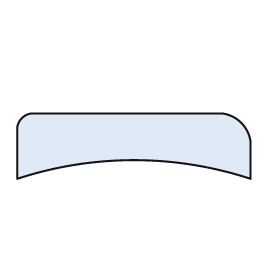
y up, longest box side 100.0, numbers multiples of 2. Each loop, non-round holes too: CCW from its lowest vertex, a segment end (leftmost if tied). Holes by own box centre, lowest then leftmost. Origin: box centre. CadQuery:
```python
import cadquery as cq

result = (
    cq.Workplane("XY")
    .moveTo(-50.0, -14.0)
    .threePointArc((0.0, -6.0), (50.0, -14.0))
    .lineTo(50.0, 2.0)
    .threePointArc((46.0, 10.0), (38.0, 14.0))
    .lineTo(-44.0, 14.0)
    .threePointArc((-48.0, 12.0), (-50.0, 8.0))
    .close()
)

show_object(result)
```